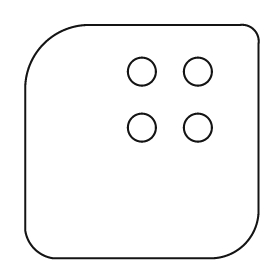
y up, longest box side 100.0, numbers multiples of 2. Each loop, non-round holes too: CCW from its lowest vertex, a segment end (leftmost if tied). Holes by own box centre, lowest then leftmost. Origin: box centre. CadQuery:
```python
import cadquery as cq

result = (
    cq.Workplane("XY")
    .moveTo(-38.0, -50.0)
    .lineTo(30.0, -50.0)
    .threePointArc((44.0, -44.0), (50.0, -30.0))
    .lineTo(50.0, 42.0)
    .threePointArc((48.0, 48.0), (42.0, 50.0))
    .lineTo(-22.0, 50.0)
    .threePointArc((-42.0, 42.0), (-50.0, 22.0))
    .lineTo(-50.0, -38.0)
    .threePointArc((-46.0, -46.0), (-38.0, -50.0))
    .close()
    .moveTo(0.0, 6.0)
    .circle(6.0)
    .moveTo(24.0, 6.0)
    .circle(6.0)
    .moveTo(0.0, 30.0)
    .circle(6.0)
    .moveTo(24.0, 30.0)
    .circle(6.0)
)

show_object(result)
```